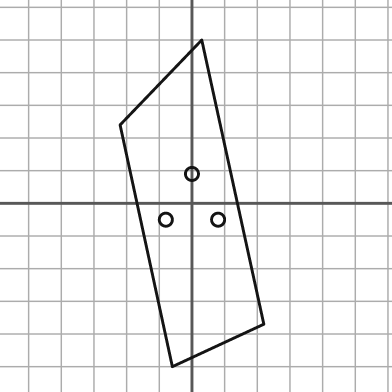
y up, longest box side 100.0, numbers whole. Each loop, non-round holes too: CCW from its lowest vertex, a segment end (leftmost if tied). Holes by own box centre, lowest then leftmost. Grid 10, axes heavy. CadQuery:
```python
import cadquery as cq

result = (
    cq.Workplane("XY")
    .moveTo(-6.0, -50.0)
    .lineTo(22.0, -37.0)
    .lineTo(3.0, 50.0)
    .lineTo(-22.0, 24.0)
    .close()
    .moveTo(-8.0, -5.0)
    .circle(2.0)
    .moveTo(8.0, -5.0)
    .circle(2.0)
    .moveTo(0.0, 9.0)
    .circle(2.0)
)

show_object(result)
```